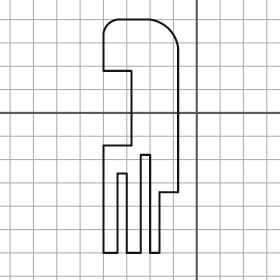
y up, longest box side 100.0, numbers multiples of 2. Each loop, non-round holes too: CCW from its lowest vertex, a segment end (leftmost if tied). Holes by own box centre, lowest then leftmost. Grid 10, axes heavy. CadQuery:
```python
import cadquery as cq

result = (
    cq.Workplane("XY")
    .moveTo(-40.0, -60.0)
    .lineTo(-34.0, -60.0)
    .lineTo(-34.0, -26.0)
    .lineTo(-30.0, -26.0)
    .lineTo(-30.0, -60.0)
    .lineTo(-24.0, -60.0)
    .lineTo(-24.0, -18.0)
    .lineTo(-20.0, -18.0)
    .lineTo(-20.0, -60.0)
    .lineTo(-16.0, -60.0)
    .lineTo(-16.0, -34.0)
    .lineTo(-8.0, -34.0)
    .lineTo(-8.0, 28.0)
    .threePointArc((-12.0, 36.0), (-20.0, 40.0))
    .lineTo(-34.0, 40.0)
    .threePointArc((-38.0, 38.0), (-40.0, 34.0))
    .lineTo(-40.0, 18.0)
    .lineTo(-28.0, 18.0)
    .lineTo(-28.0, -14.0)
    .lineTo(-40.0, -14.0)
    .close()
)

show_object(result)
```